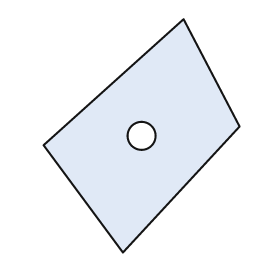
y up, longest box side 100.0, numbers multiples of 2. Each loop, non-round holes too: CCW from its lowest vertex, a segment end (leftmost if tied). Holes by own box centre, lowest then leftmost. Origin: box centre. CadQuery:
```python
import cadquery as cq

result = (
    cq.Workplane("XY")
    .moveTo(-8.0, -50.0)
    .lineTo(42.0, 4.0)
    .lineTo(18.0, 50.0)
    .lineTo(-42.0, -4.0)
    .close()
    .moveTo(0.0, 0.0)
    .circle(6.0)
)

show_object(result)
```